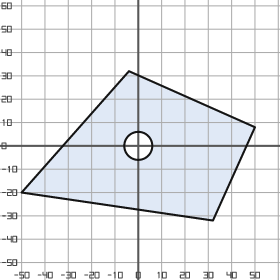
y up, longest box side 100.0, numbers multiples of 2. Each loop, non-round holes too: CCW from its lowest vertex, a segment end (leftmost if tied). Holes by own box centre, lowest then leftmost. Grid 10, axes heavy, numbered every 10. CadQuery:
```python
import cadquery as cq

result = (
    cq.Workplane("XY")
    .moveTo(32.0, -32.0)
    .lineTo(50.0, 8.0)
    .lineTo(-4.0, 32.0)
    .lineTo(-50.0, -20.0)
    .close()
    .moveTo(0.0, 0.0)
    .circle(6.0)
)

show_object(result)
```